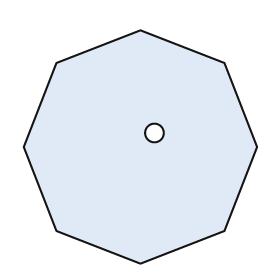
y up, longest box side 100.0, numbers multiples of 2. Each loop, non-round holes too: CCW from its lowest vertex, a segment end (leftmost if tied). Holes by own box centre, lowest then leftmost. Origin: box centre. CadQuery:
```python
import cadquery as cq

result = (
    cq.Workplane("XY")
    .moveTo(0.0, -50.0)
    .lineTo(36.0, -36.0)
    .lineTo(50.0, 0.0)
    .lineTo(36.0, 36.0)
    .lineTo(0.0, 50.0)
    .lineTo(-36.0, 36.0)
    .lineTo(-50.0, 0.0)
    .lineTo(-36.0, -36.0)
    .close()
    .moveTo(6.0, 6.0)
    .circle(4.0)
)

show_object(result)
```